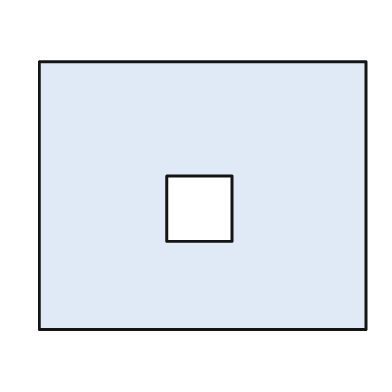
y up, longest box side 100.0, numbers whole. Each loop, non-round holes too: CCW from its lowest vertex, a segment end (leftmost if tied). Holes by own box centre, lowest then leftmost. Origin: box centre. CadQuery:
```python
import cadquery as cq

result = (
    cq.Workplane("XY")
    .moveTo(-50.0, -41.0)
    .lineTo(50.0, -41.0)
    .lineTo(50.0, 41.0)
    .lineTo(-50.0, 41.0)
    .close()
    .moveTo(-11.0, -14.0)
    .lineTo(9.0, -14.0)
    .lineTo(9.0, 6.0)
    .lineTo(-11.0, 6.0)
    .close()
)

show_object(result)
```